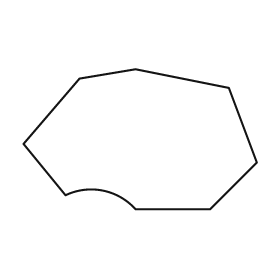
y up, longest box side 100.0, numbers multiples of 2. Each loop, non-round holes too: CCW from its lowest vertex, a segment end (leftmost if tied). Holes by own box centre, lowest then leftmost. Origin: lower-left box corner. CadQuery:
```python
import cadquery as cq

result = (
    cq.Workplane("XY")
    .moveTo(48.0, 0.0)
    .lineTo(80.0, 0.0)
    .lineTo(100.0, 20.0)
    .lineTo(88.0, 52.0)
    .lineTo(48.0, 60.0)
    .lineTo(24.0, 56.0)
    .lineTo(0.0, 28.0)
    .lineTo(18.0, 6.0)
    .threePointArc((34.0, 8.0), (48.0, 0.0))
    .close()
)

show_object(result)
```